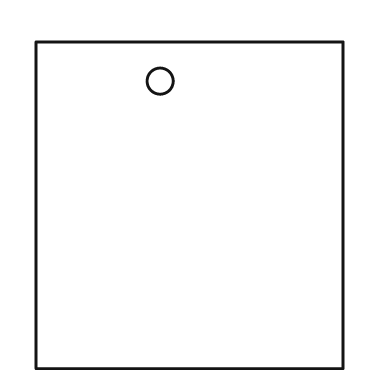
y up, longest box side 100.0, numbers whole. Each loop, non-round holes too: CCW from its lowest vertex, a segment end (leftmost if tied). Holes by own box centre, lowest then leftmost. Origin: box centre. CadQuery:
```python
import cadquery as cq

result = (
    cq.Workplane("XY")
    .moveTo(-47.0, -50.0)
    .lineTo(47.0, -50.0)
    .lineTo(47.0, 50.0)
    .lineTo(-47.0, 50.0)
    .close()
    .moveTo(-9.0, 38.0)
    .circle(4.0)
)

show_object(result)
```